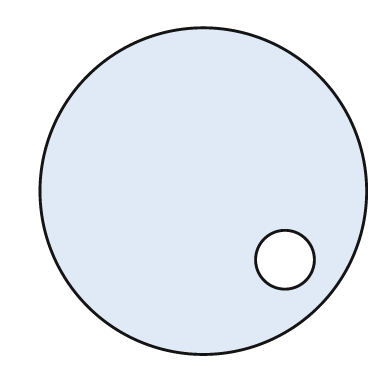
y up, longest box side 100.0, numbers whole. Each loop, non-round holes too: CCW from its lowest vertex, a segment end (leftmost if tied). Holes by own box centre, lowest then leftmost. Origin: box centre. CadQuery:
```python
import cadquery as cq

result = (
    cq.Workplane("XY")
    .moveTo(0.0, 0.0)
    .circle(50.0)
    .moveTo(25.0, -21.0)
    .circle(9.0)
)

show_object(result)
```